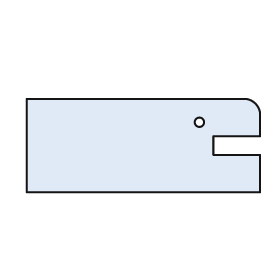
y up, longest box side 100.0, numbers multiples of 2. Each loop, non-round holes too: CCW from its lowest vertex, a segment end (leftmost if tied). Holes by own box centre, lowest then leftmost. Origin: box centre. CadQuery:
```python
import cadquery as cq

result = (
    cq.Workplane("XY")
    .moveTo(-50.0, -20.0)
    .lineTo(50.0, -20.0)
    .lineTo(50.0, -4.0)
    .lineTo(30.0, -4.0)
    .lineTo(30.0, 4.0)
    .lineTo(50.0, 4.0)
    .lineTo(50.0, 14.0)
    .threePointArc((48.0, 18.0), (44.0, 20.0))
    .lineTo(-50.0, 20.0)
    .close()
    .moveTo(24.0, 10.0)
    .circle(2.0)
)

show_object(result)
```